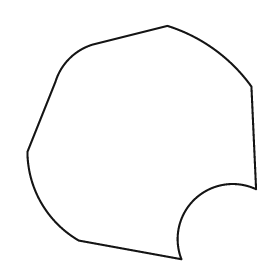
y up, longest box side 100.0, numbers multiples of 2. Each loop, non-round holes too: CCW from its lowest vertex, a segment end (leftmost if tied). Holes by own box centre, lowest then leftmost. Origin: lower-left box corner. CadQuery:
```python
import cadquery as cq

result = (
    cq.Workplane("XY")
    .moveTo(66.0, 0.0)
    .threePointArc((72.0, 26.0), (98.0, 30.0))
    .lineTo(96.0, 74.0)
    .threePointArc((80.0, 90.0), (60.0, 100.0))
    .lineTo(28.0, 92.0)
    .threePointArc((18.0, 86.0), (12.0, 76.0))
    .lineTo(0.0, 46.0)
    .threePointArc((6.0, 24.0), (22.0, 8.0))
    .close()
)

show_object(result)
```